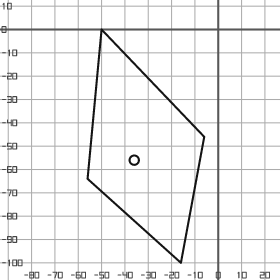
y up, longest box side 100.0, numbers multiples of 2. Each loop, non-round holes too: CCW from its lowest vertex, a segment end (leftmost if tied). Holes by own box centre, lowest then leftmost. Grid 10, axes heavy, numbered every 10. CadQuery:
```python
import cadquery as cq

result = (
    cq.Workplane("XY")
    .moveTo(-16.0, -100.0)
    .lineTo(-6.0, -46.0)
    .lineTo(-50.0, 0.0)
    .lineTo(-56.0, -64.0)
    .close()
    .moveTo(-36.0, -56.0)
    .circle(2.0)
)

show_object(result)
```